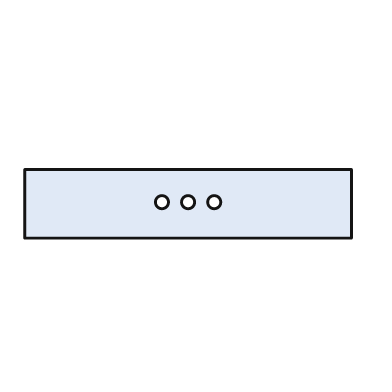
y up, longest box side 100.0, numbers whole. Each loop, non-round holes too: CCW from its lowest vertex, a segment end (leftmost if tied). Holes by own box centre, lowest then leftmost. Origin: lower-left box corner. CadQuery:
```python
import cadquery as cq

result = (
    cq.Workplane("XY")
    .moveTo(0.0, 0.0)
    .lineTo(100.0, 0.0)
    .lineTo(100.0, 21.0)
    .lineTo(0.0, 21.0)
    .close()
    .moveTo(42.0, 11.0)
    .circle(2.0)
    .moveTo(50.0, 11.0)
    .circle(2.0)
    .moveTo(58.0, 11.0)
    .circle(2.0)
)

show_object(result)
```